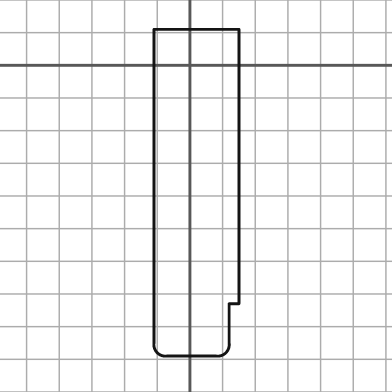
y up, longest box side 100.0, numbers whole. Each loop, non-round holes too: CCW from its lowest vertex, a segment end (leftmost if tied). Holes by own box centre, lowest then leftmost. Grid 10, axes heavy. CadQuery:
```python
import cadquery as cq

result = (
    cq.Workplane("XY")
    .moveTo(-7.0, -89.0)
    .lineTo(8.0, -89.0)
    .threePointArc((11.0, -88.0), (12.0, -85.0))
    .lineTo(12.0, -73.0)
    .lineTo(15.0, -73.0)
    .lineTo(15.0, 11.0)
    .lineTo(-11.0, 11.0)
    .lineTo(-11.0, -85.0)
    .threePointArc((-10.0, -88.0), (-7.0, -89.0))
    .close()
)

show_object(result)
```